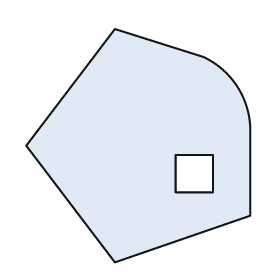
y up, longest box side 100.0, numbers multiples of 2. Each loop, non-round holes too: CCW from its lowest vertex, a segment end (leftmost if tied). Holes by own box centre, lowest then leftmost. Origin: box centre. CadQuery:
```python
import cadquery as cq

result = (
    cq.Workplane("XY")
    .moveTo(-10.0, -50.0)
    .lineTo(48.0, -30.0)
    .lineTo(48.0, 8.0)
    .threePointArc((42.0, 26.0), (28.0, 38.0))
    .lineTo(-10.0, 50.0)
    .lineTo(-48.0, 0.0)
    .close()
    .moveTo(16.0, -20.0)
    .lineTo(32.0, -20.0)
    .lineTo(32.0, -4.0)
    .lineTo(16.0, -4.0)
    .close()
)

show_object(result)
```